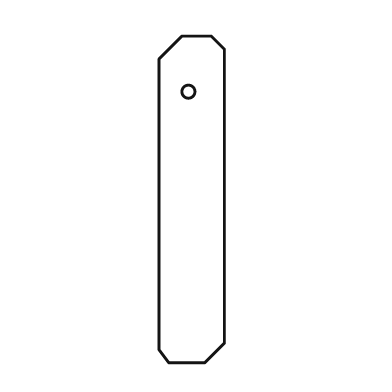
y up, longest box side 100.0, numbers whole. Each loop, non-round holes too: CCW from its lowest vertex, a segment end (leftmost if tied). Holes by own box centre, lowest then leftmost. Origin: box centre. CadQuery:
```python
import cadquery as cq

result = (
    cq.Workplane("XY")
    .moveTo(-7.0, -50.0)
    .lineTo(4.0, -50.0)
    .lineTo(10.0, -44.0)
    .lineTo(10.0, 46.0)
    .lineTo(6.0, 50.0)
    .lineTo(-3.0, 50.0)
    .lineTo(-10.0, 43.0)
    .lineTo(-10.0, -46.0)
    .close()
    .moveTo(-1.0, 33.0)
    .circle(2.0)
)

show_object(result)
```